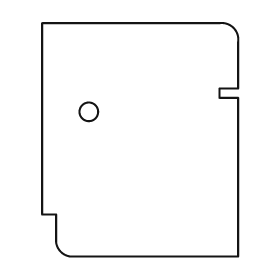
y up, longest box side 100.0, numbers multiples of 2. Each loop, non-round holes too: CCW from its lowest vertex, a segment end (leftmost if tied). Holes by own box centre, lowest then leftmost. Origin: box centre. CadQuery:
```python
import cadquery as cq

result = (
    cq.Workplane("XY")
    .moveTo(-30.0, -50.0)
    .lineTo(42.0, -50.0)
    .lineTo(42.0, 18.0)
    .lineTo(34.0, 18.0)
    .lineTo(34.0, 22.0)
    .lineTo(42.0, 22.0)
    .lineTo(42.0, 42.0)
    .threePointArc((40.0, 48.0), (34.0, 50.0))
    .lineTo(-42.0, 50.0)
    .lineTo(-42.0, -32.0)
    .lineTo(-36.0, -32.0)
    .lineTo(-36.0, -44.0)
    .threePointArc((-34.0, -48.0), (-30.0, -50.0))
    .close()
    .moveTo(-22.0, 12.0)
    .circle(4.0)
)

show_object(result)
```